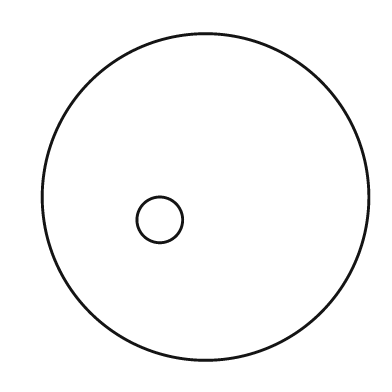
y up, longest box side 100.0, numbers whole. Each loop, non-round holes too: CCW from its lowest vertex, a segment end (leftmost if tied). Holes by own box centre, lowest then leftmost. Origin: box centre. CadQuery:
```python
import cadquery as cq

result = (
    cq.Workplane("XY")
    .moveTo(0.0, 0.0)
    .circle(50.0)
    .moveTo(-14.0, -7.0)
    .circle(7.0)
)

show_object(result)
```